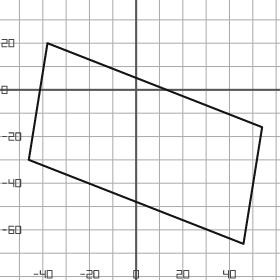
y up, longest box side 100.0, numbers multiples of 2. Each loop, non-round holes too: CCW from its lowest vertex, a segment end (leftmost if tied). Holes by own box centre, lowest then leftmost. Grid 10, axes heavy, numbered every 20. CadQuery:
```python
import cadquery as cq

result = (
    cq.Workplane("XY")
    .moveTo(46.0, -66.0)
    .lineTo(54.0, -16.0)
    .lineTo(-38.0, 20.0)
    .lineTo(-46.0, -30.0)
    .close()
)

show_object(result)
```